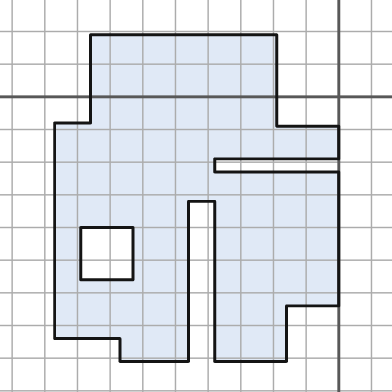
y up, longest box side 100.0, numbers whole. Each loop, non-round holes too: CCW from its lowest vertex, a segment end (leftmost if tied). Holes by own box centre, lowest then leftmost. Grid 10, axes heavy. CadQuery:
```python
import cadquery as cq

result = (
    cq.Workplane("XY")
    .moveTo(-67.0, -81.0)
    .lineTo(-46.0, -81.0)
    .lineTo(-46.0, -32.0)
    .lineTo(-38.0, -32.0)
    .lineTo(-38.0, -81.0)
    .lineTo(-16.0, -81.0)
    .lineTo(-16.0, -64.0)
    .lineTo(0.0, -64.0)
    .lineTo(0.0, -23.0)
    .lineTo(-38.0, -23.0)
    .lineTo(-38.0, -19.0)
    .lineTo(0.0, -19.0)
    .lineTo(0.0, -9.0)
    .lineTo(-19.0, -9.0)
    .lineTo(-19.0, 19.0)
    .lineTo(-76.0, 19.0)
    .lineTo(-76.0, -8.0)
    .lineTo(-87.0, -8.0)
    .lineTo(-87.0, -74.0)
    .lineTo(-67.0, -74.0)
    .close()
    .moveTo(-79.0, -56.0)
    .lineTo(-63.0, -56.0)
    .lineTo(-63.0, -40.0)
    .lineTo(-79.0, -40.0)
    .close()
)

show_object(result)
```